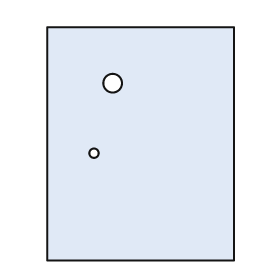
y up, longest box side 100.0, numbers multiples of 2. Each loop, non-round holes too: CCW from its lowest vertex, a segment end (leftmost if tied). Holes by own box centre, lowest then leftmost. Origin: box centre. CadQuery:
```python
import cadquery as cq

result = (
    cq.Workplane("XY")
    .moveTo(-40.0, -50.0)
    .lineTo(40.0, -50.0)
    .lineTo(40.0, 50.0)
    .lineTo(-40.0, 50.0)
    .close()
    .moveTo(-20.0, -4.0)
    .circle(2.0)
    .moveTo(-12.0, 26.0)
    .circle(4.0)
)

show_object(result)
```